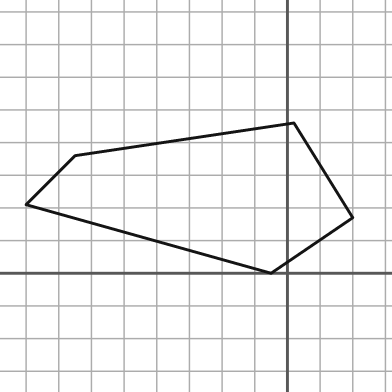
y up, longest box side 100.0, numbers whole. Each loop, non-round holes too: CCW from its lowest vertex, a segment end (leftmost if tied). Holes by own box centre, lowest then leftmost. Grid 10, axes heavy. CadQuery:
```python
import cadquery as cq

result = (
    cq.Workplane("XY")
    .moveTo(-5.0, 0.0)
    .lineTo(20.0, 17.0)
    .lineTo(2.0, 46.0)
    .lineTo(-65.0, 36.0)
    .lineTo(-80.0, 21.0)
    .close()
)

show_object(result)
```